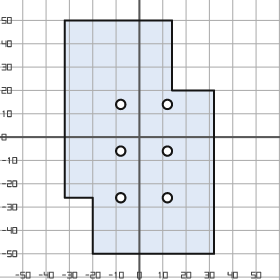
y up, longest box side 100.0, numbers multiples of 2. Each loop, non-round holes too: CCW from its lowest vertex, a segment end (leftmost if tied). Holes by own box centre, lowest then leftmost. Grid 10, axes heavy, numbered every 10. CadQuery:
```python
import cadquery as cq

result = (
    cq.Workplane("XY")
    .moveTo(-20.0, -50.0)
    .lineTo(32.0, -50.0)
    .lineTo(32.0, 20.0)
    .lineTo(14.0, 20.0)
    .lineTo(14.0, 50.0)
    .lineTo(-32.0, 50.0)
    .lineTo(-32.0, -26.0)
    .lineTo(-20.0, -26.0)
    .close()
    .moveTo(-8.0, -26.0)
    .circle(2.0)
    .moveTo(12.0, -26.0)
    .circle(2.0)
    .moveTo(-8.0, -6.0)
    .circle(2.0)
    .moveTo(12.0, -6.0)
    .circle(2.0)
    .moveTo(-8.0, 14.0)
    .circle(2.0)
    .moveTo(12.0, 14.0)
    .circle(2.0)
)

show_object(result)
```